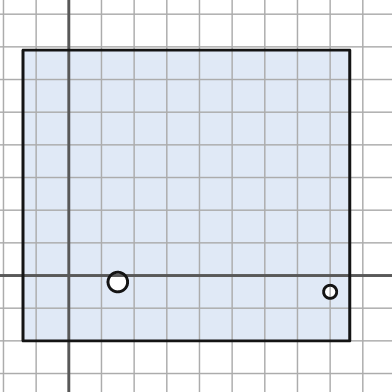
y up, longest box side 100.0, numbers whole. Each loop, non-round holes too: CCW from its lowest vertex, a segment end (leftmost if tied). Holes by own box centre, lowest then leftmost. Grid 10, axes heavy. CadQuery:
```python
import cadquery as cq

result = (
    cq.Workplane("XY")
    .moveTo(-14.0, -20.0)
    .lineTo(86.0, -20.0)
    .lineTo(86.0, 69.0)
    .lineTo(-14.0, 69.0)
    .close()
    .moveTo(80.0, -5.0)
    .circle(2.0)
    .moveTo(15.0, -2.0)
    .circle(3.0)
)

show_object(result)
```